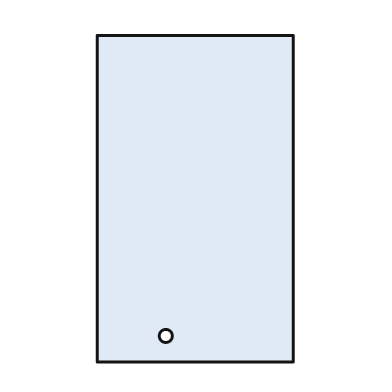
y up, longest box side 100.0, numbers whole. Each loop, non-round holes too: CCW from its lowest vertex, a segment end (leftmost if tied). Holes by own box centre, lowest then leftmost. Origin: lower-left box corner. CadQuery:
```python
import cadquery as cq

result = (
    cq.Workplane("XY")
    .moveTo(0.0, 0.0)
    .lineTo(60.0, 0.0)
    .lineTo(60.0, 100.0)
    .lineTo(0.0, 100.0)
    .close()
    .moveTo(21.0, 8.0)
    .circle(2.0)
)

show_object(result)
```